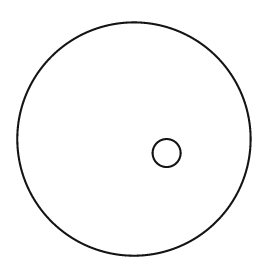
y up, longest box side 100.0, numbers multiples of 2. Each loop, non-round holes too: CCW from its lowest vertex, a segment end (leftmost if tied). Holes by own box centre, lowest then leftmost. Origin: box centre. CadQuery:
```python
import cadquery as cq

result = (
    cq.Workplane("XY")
    .moveTo(0.0, 0.0)
    .circle(50.0)
    .moveTo(14.0, -6.0)
    .circle(6.0)
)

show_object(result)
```